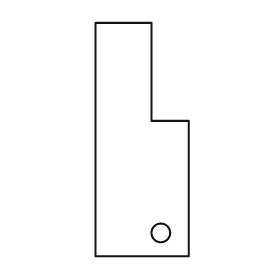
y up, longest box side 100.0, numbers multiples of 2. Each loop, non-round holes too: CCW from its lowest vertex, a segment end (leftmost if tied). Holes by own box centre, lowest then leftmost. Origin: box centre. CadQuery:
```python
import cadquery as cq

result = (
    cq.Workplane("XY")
    .moveTo(-20.0, -50.0)
    .lineTo(20.0, -50.0)
    .lineTo(20.0, 8.0)
    .lineTo(4.0, 8.0)
    .lineTo(4.0, 50.0)
    .lineTo(-20.0, 50.0)
    .close()
    .moveTo(8.0, -40.0)
    .circle(4.0)
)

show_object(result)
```